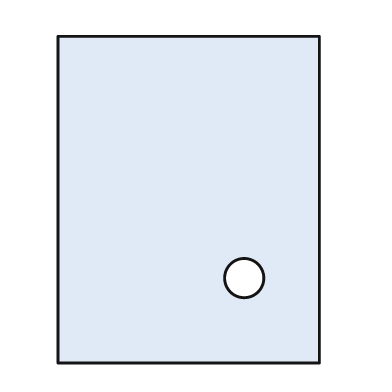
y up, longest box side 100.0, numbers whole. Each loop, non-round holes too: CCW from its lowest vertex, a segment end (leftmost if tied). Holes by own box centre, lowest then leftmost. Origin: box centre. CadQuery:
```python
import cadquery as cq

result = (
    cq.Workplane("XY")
    .moveTo(-40.0, -50.0)
    .lineTo(40.0, -50.0)
    .lineTo(40.0, 50.0)
    .lineTo(-40.0, 50.0)
    .close()
    .moveTo(17.0, -24.0)
    .circle(6.0)
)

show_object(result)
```